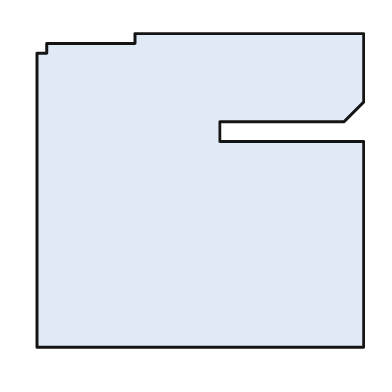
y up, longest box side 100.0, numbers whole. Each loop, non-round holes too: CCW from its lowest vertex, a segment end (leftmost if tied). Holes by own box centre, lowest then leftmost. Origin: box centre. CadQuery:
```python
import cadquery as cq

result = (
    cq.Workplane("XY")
    .moveTo(-50.0, -48.0)
    .lineTo(50.0, -48.0)
    .lineTo(50.0, 15.0)
    .lineTo(6.0, 15.0)
    .lineTo(6.0, 21.0)
    .lineTo(44.0, 21.0)
    .lineTo(50.0, 27.0)
    .lineTo(50.0, 48.0)
    .lineTo(-20.0, 48.0)
    .lineTo(-20.0, 45.0)
    .lineTo(-47.0, 45.0)
    .lineTo(-47.0, 42.0)
    .lineTo(-50.0, 42.0)
    .close()
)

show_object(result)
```